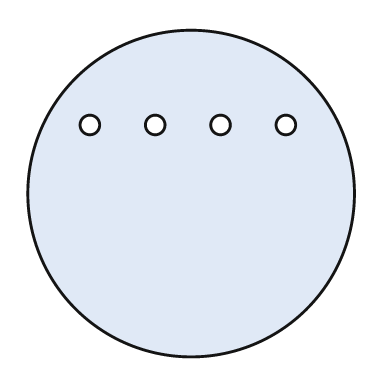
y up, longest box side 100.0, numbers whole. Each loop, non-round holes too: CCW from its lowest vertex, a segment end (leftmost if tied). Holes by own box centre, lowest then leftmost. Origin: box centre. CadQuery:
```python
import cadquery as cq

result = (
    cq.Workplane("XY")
    .moveTo(0.0, 0.0)
    .circle(50.0)
    .moveTo(-31.0, 21.0)
    .circle(3.0)
    .moveTo(-11.0, 21.0)
    .circle(3.0)
    .moveTo(9.0, 21.0)
    .circle(3.0)
    .moveTo(29.0, 21.0)
    .circle(3.0)
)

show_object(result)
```